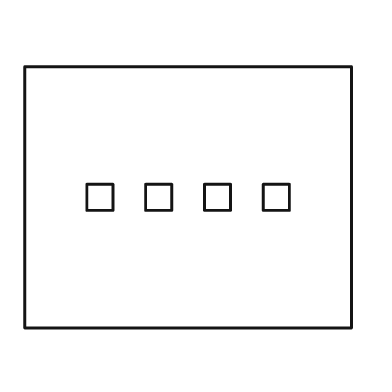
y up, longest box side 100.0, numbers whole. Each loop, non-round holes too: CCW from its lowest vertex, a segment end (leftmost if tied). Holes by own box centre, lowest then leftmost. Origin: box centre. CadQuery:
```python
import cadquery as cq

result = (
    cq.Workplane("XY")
    .moveTo(-50.0, -40.0)
    .lineTo(50.0, -40.0)
    .lineTo(50.0, 40.0)
    .lineTo(-50.0, 40.0)
    .close()
    .moveTo(-31.0, -4.0)
    .lineTo(-23.0, -4.0)
    .lineTo(-23.0, 4.0)
    .lineTo(-31.0, 4.0)
    .close()
    .moveTo(-13.0, -4.0)
    .lineTo(-5.0, -4.0)
    .lineTo(-5.0, 4.0)
    .lineTo(-13.0, 4.0)
    .close()
    .moveTo(5.0, -4.0)
    .lineTo(13.0, -4.0)
    .lineTo(13.0, 4.0)
    .lineTo(5.0, 4.0)
    .close()
    .moveTo(23.0, -4.0)
    .lineTo(31.0, -4.0)
    .lineTo(31.0, 4.0)
    .lineTo(23.0, 4.0)
    .close()
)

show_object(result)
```